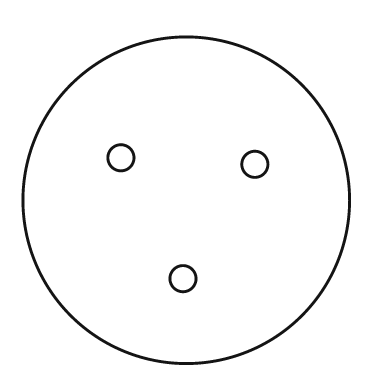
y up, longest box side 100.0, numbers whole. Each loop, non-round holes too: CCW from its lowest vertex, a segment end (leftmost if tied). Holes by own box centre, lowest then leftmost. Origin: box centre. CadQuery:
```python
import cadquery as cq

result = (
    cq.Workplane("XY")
    .moveTo(0.0, 0.0)
    .circle(50.0)
    .moveTo(-1.0, -24.0)
    .circle(4.0)
    .moveTo(21.0, 11.0)
    .circle(4.0)
    .moveTo(-20.0, 13.0)
    .circle(4.0)
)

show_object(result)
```